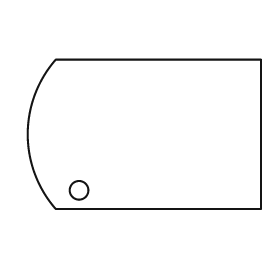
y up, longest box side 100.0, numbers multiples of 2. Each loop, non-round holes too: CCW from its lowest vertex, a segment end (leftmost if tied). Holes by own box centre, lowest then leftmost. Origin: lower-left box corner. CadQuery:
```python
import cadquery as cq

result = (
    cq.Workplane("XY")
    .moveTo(12.0, 0.0)
    .lineTo(100.0, 0.0)
    .lineTo(100.0, 64.0)
    .lineTo(12.0, 64.0)
    .threePointArc((0.0, 32.0), (12.0, 0.0))
    .close()
    .moveTo(22.0, 8.0)
    .circle(4.0)
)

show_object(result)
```